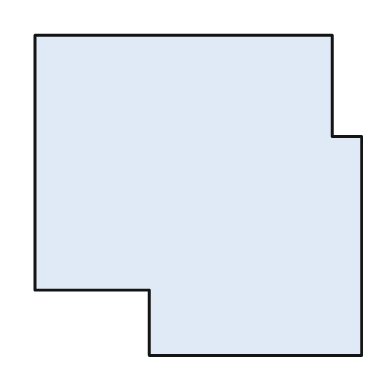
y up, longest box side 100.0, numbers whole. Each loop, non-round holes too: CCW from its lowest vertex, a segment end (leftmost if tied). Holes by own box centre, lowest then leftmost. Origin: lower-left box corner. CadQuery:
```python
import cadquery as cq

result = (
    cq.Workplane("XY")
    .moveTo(35.0, 0.0)
    .lineTo(100.0, 0.0)
    .lineTo(100.0, 67.0)
    .lineTo(91.0, 67.0)
    .lineTo(91.0, 98.0)
    .lineTo(0.0, 98.0)
    .lineTo(0.0, 20.0)
    .lineTo(35.0, 20.0)
    .close()
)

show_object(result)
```